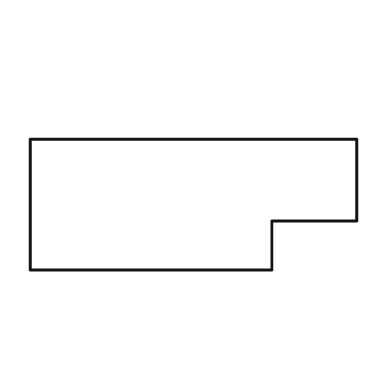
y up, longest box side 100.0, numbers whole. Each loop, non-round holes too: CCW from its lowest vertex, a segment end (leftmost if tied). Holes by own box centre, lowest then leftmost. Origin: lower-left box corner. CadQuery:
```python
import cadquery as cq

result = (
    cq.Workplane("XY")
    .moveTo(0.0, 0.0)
    .lineTo(74.0, 0.0)
    .lineTo(74.0, 15.0)
    .lineTo(100.0, 15.0)
    .lineTo(100.0, 40.0)
    .lineTo(0.0, 40.0)
    .close()
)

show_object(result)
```